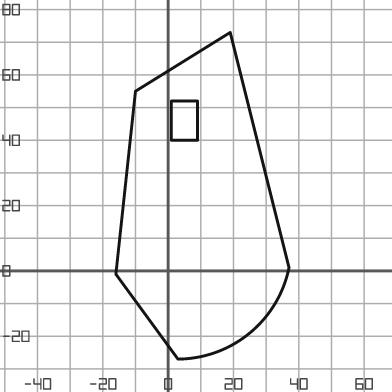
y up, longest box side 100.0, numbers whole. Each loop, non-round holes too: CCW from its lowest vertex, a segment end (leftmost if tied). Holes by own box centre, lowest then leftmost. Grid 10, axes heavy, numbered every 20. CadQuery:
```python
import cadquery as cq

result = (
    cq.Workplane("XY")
    .moveTo(3.0, -27.0)
    .threePointArc((25.0, -19.0), (37.0, 1.0))
    .lineTo(19.0, 73.0)
    .lineTo(-10.0, 55.0)
    .lineTo(-16.0, -1.0)
    .close()
    .moveTo(1.0, 40.0)
    .lineTo(9.0, 40.0)
    .lineTo(9.0, 52.0)
    .lineTo(1.0, 52.0)
    .close()
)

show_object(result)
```